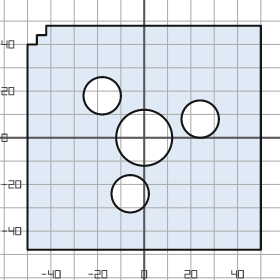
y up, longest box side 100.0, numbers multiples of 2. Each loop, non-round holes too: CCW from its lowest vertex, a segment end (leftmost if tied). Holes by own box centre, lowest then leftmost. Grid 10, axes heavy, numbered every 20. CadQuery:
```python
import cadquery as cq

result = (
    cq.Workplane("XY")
    .moveTo(-50.0, -48.0)
    .lineTo(50.0, -48.0)
    .lineTo(50.0, 48.0)
    .lineTo(-42.0, 48.0)
    .lineTo(-42.0, 44.0)
    .lineTo(-46.0, 44.0)
    .lineTo(-46.0, 40.0)
    .lineTo(-50.0, 40.0)
    .close()
    .moveTo(-6.0, -24.0)
    .circle(8.0)
    .moveTo(0.0, 0.0)
    .circle(12.0)
    .moveTo(24.0, 8.0)
    .circle(8.0)
    .moveTo(-18.0, 18.0)
    .circle(8.0)
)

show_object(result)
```